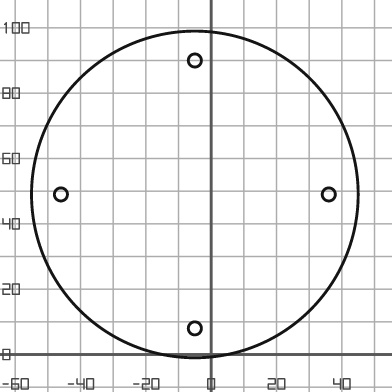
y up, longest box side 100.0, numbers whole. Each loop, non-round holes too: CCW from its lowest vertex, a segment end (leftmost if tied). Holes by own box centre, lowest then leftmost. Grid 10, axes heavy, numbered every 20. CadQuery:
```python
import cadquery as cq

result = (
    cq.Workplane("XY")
    .moveTo(-5.0, 49.0)
    .circle(50.0)
    .moveTo(-5.0, 8.0)
    .circle(2.0)
    .moveTo(-46.0, 49.0)
    .circle(2.0)
    .moveTo(36.0, 49.0)
    .circle(2.0)
    .moveTo(-5.0, 90.0)
    .circle(2.0)
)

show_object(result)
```